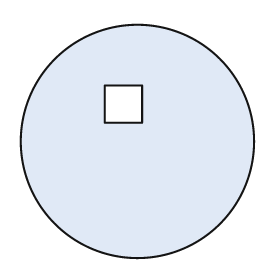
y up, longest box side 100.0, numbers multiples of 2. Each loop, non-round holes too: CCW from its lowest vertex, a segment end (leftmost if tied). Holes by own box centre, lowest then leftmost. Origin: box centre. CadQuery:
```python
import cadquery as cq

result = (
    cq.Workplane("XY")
    .moveTo(0.0, 0.0)
    .circle(50.0)
    .moveTo(-14.0, 8.0)
    .lineTo(2.0, 8.0)
    .lineTo(2.0, 24.0)
    .lineTo(-14.0, 24.0)
    .close()
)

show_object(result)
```